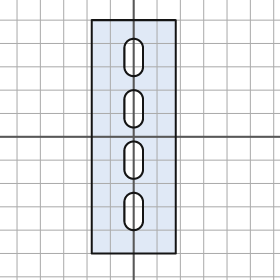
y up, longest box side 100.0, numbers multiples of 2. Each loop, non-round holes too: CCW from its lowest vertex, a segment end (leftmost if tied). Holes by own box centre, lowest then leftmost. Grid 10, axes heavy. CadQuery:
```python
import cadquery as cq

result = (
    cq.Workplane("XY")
    .moveTo(-18.0, -50.0)
    .lineTo(18.0, -50.0)
    .lineTo(18.0, 50.0)
    .lineTo(-18.0, 50.0)
    .close()
    .moveTo(-4.0, -36.0)
    .threePointArc((0.0, -40.0), (4.0, -36.0))
    .lineTo(4.0, -28.0)
    .threePointArc((0.0, -24.0), (-4.0, -28.0))
    .close()
    .moveTo(-4.0, -14.0)
    .threePointArc((0.0, -18.0), (4.0, -14.0))
    .lineTo(4.0, -6.0)
    .threePointArc((0.0, -2.0), (-4.0, -6.0))
    .close()
    .moveTo(-4.0, 8.0)
    .threePointArc((0.0, 4.0), (4.0, 8.0))
    .lineTo(4.0, 16.0)
    .threePointArc((0.0, 20.0), (-4.0, 16.0))
    .close()
    .moveTo(-4.0, 30.0)
    .threePointArc((0.0, 26.0), (4.0, 30.0))
    .lineTo(4.0, 38.0)
    .threePointArc((0.0, 42.0), (-4.0, 38.0))
    .close()
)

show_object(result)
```